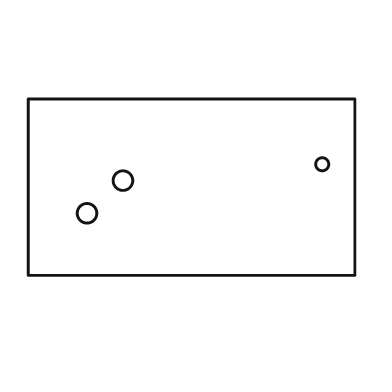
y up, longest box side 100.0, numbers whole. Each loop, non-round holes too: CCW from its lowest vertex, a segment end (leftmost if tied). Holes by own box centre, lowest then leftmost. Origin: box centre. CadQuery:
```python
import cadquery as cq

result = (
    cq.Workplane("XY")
    .moveTo(-50.0, -27.0)
    .lineTo(50.0, -27.0)
    .lineTo(50.0, 27.0)
    .lineTo(-50.0, 27.0)
    .close()
    .moveTo(-32.0, -8.0)
    .circle(3.0)
    .moveTo(-21.0, 2.0)
    .circle(3.0)
    .moveTo(40.0, 7.0)
    .circle(2.0)
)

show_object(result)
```